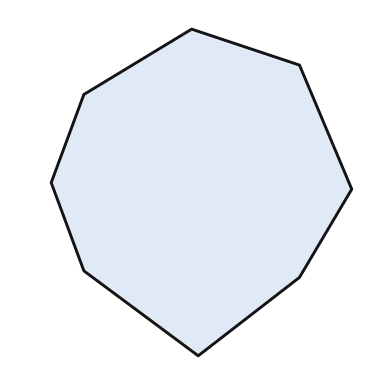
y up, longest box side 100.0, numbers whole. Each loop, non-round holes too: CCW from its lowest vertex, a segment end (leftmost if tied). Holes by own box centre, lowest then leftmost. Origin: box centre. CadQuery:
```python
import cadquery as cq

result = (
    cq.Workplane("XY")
    .moveTo(-1.0, -50.0)
    .lineTo(30.0, -26.0)
    .lineTo(46.0, 1.0)
    .lineTo(30.0, 39.0)
    .lineTo(-3.0, 50.0)
    .lineTo(-36.0, 30.0)
    .lineTo(-46.0, 3.0)
    .lineTo(-36.0, -24.0)
    .close()
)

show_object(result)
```